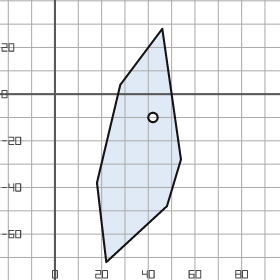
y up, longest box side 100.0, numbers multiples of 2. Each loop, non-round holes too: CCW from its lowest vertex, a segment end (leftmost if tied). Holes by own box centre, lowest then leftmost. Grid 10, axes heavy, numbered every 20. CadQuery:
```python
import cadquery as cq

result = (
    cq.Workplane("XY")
    .moveTo(22.0, -72.0)
    .lineTo(48.0, -48.0)
    .lineTo(54.0, -28.0)
    .lineTo(46.0, 28.0)
    .lineTo(28.0, 4.0)
    .lineTo(18.0, -38.0)
    .close()
    .moveTo(42.0, -10.0)
    .circle(2.0)
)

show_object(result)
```